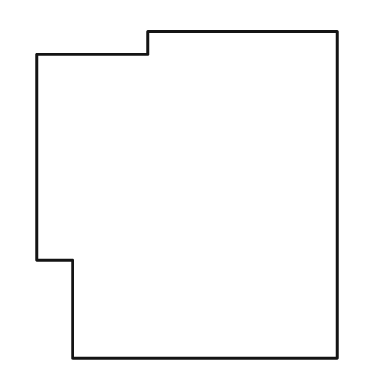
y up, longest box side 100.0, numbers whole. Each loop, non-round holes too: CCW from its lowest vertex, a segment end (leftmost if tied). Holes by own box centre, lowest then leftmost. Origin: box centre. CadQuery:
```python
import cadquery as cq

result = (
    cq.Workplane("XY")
    .moveTo(-35.0, -50.0)
    .lineTo(46.0, -50.0)
    .lineTo(46.0, 50.0)
    .lineTo(-12.0, 50.0)
    .lineTo(-12.0, 43.0)
    .lineTo(-46.0, 43.0)
    .lineTo(-46.0, -20.0)
    .lineTo(-35.0, -20.0)
    .close()
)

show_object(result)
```